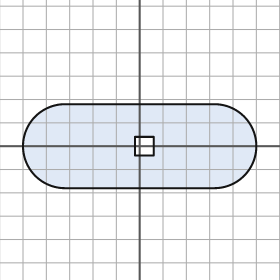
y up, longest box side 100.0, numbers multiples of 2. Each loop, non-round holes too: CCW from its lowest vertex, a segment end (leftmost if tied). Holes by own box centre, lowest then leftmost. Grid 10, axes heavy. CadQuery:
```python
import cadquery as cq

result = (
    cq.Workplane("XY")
    .moveTo(-32.0, -18.0)
    .lineTo(32.0, -18.0)
    .threePointArc((50.0, 0.0), (32.0, 18.0))
    .lineTo(-32.0, 18.0)
    .threePointArc((-50.0, 0.0), (-32.0, -18.0))
    .close()
    .moveTo(-2.0, -4.0)
    .lineTo(6.0, -4.0)
    .lineTo(6.0, 4.0)
    .lineTo(-2.0, 4.0)
    .close()
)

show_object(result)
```